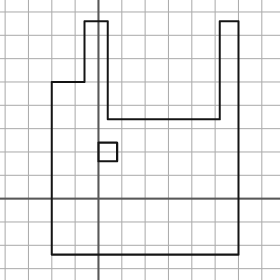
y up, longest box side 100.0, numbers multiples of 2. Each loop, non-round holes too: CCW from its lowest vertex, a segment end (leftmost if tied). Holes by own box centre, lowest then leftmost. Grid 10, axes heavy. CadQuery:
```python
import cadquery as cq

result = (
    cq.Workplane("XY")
    .moveTo(-20.0, -24.0)
    .lineTo(60.0, -24.0)
    .lineTo(60.0, 76.0)
    .lineTo(52.0, 76.0)
    .lineTo(52.0, 34.0)
    .lineTo(4.0, 34.0)
    .lineTo(4.0, 76.0)
    .lineTo(-6.0, 76.0)
    .lineTo(-6.0, 50.0)
    .lineTo(-20.0, 50.0)
    .close()
    .moveTo(0.0, 16.0)
    .lineTo(8.0, 16.0)
    .lineTo(8.0, 24.0)
    .lineTo(0.0, 24.0)
    .close()
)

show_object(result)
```